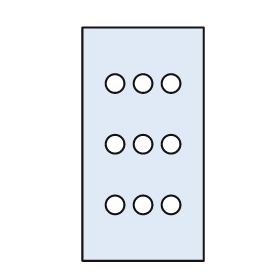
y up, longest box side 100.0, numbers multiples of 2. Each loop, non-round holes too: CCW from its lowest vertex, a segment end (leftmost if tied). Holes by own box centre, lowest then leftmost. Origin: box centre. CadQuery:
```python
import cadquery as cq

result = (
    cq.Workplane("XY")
    .moveTo(-26.0, -50.0)
    .lineTo(26.0, -50.0)
    .lineTo(26.0, 50.0)
    .lineTo(-26.0, 50.0)
    .close()
    .moveTo(-12.0, -26.0)
    .circle(4.0)
    .moveTo(0.0, -26.0)
    .circle(4.0)
    .moveTo(12.0, -26.0)
    .circle(4.0)
    .moveTo(-12.0, 0.0)
    .circle(4.0)
    .moveTo(0.0, 0.0)
    .circle(4.0)
    .moveTo(12.0, 0.0)
    .circle(4.0)
    .moveTo(-12.0, 26.0)
    .circle(4.0)
    .moveTo(0.0, 26.0)
    .circle(4.0)
    .moveTo(12.0, 26.0)
    .circle(4.0)
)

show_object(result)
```